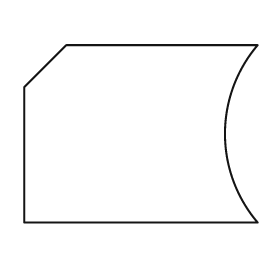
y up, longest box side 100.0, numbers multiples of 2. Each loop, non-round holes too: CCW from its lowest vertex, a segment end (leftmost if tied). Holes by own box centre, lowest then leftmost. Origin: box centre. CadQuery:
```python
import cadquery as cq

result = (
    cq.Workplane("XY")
    .moveTo(-50.0, -38.0)
    .lineTo(50.0, -38.0)
    .threePointArc((36.0, 0.0), (50.0, 38.0))
    .lineTo(-32.0, 38.0)
    .lineTo(-50.0, 20.0)
    .close()
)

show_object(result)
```